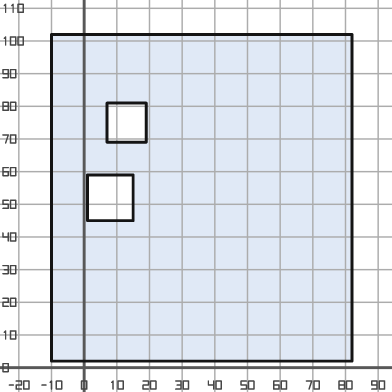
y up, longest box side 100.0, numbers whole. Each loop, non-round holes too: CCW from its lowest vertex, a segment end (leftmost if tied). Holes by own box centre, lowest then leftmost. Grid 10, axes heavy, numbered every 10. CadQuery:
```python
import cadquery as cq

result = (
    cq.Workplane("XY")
    .moveTo(-10.0, 2.0)
    .lineTo(82.0, 2.0)
    .lineTo(82.0, 102.0)
    .lineTo(-10.0, 102.0)
    .close()
    .moveTo(1.0, 45.0)
    .lineTo(15.0, 45.0)
    .lineTo(15.0, 59.0)
    .lineTo(1.0, 59.0)
    .close()
    .moveTo(7.0, 69.0)
    .lineTo(19.0, 69.0)
    .lineTo(19.0, 81.0)
    .lineTo(7.0, 81.0)
    .close()
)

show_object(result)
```